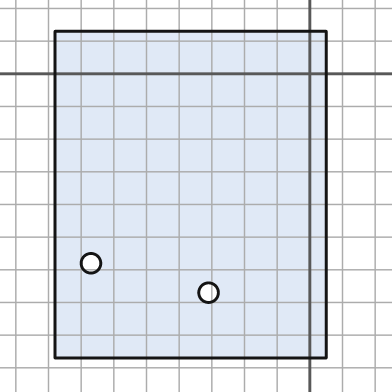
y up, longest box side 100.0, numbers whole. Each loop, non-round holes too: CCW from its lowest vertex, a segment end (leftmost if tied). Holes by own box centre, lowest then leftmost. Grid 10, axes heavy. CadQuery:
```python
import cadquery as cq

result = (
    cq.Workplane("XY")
    .moveTo(-78.0, -87.0)
    .lineTo(5.0, -87.0)
    .lineTo(5.0, 13.0)
    .lineTo(-78.0, 13.0)
    .close()
    .moveTo(-31.0, -67.0)
    .circle(3.0)
    .moveTo(-67.0, -58.0)
    .circle(3.0)
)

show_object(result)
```